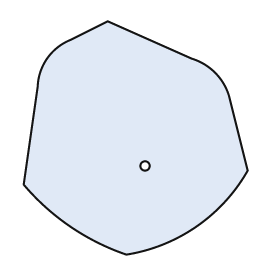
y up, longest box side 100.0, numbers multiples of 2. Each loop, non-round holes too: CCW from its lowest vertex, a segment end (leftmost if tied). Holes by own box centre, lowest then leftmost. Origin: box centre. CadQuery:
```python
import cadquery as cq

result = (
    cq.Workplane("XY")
    .moveTo(-4.0, -50.0)
    .threePointArc((26.0, -38.0), (48.0, -14.0))
    .lineTo(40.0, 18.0)
    .threePointArc((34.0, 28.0), (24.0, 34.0))
    .lineTo(-12.0, 50.0)
    .lineTo(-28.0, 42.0)
    .threePointArc((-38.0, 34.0), (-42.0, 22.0))
    .lineTo(-48.0, -20.0)
    .threePointArc((-28.0, -38.0), (-4.0, -50.0))
    .close()
    .moveTo(4.0, -12.0)
    .circle(2.0)
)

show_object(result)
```